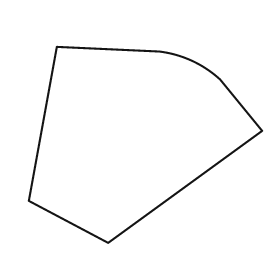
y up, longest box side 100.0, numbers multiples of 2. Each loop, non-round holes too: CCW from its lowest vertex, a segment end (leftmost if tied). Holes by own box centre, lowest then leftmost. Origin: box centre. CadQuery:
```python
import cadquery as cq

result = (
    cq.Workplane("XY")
    .moveTo(-16.0, -42.0)
    .lineTo(50.0, 6.0)
    .lineTo(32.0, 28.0)
    .threePointArc((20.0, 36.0), (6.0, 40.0))
    .lineTo(-38.0, 42.0)
    .lineTo(-50.0, -24.0)
    .close()
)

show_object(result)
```